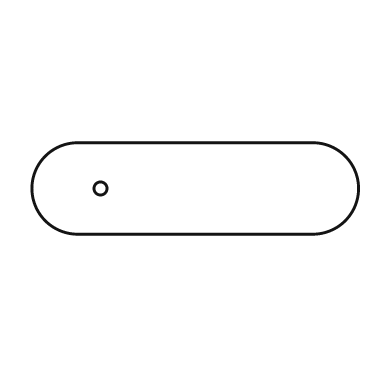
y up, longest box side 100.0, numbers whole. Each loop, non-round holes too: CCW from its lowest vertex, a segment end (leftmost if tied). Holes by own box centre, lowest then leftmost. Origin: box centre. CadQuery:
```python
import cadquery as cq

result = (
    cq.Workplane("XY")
    .moveTo(-36.0, -14.0)
    .lineTo(36.0, -14.0)
    .threePointArc((50.0, 0.0), (36.0, 14.0))
    .lineTo(-36.0, 14.0)
    .threePointArc((-50.0, 0.0), (-36.0, -14.0))
    .close()
    .moveTo(-29.0, 0.0)
    .circle(2.0)
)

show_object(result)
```